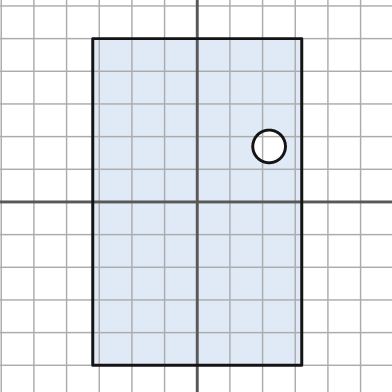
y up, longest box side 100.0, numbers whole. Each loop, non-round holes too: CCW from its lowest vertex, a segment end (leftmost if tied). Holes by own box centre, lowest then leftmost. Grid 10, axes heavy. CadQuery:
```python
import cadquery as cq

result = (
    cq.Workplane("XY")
    .moveTo(-32.0, -50.0)
    .lineTo(32.0, -50.0)
    .lineTo(32.0, 50.0)
    .lineTo(-32.0, 50.0)
    .close()
    .moveTo(22.0, 17.0)
    .circle(5.0)
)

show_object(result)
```